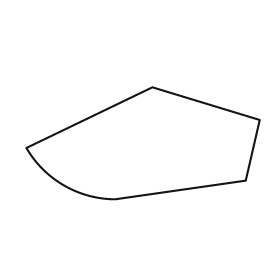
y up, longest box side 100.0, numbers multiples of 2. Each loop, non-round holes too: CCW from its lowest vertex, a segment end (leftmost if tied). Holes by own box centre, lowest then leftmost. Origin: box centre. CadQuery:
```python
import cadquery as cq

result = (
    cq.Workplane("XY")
    .moveTo(-12.0, -24.0)
    .lineTo(44.0, -16.0)
    .lineTo(50.0, 10.0)
    .lineTo(4.0, 24.0)
    .lineTo(-50.0, -2.0)
    .threePointArc((-34.0, -18.0), (-12.0, -24.0))
    .close()
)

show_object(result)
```